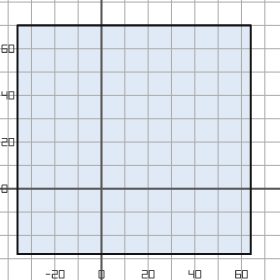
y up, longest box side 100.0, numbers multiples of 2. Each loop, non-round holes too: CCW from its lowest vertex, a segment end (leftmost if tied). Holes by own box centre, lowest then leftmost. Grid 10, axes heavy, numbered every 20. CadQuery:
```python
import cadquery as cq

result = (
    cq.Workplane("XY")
    .moveTo(-36.0, -28.0)
    .lineTo(64.0, -28.0)
    .lineTo(64.0, 70.0)
    .lineTo(-36.0, 70.0)
    .close()
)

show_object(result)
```